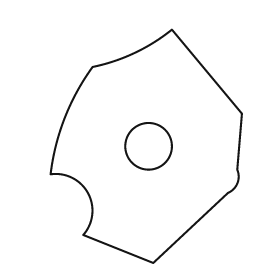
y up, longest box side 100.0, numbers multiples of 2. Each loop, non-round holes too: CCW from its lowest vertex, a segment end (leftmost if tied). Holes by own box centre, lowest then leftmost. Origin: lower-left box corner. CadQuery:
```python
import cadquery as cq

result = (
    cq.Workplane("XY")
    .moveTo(44.0, 0.0)
    .lineTo(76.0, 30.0)
    .threePointArc((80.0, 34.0), (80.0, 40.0))
    .lineTo(82.0, 64.0)
    .lineTo(52.0, 100.0)
    .threePointArc((36.0, 90.0), (18.0, 84.0))
    .threePointArc((6.0, 62.0), (0.0, 38.0))
    .threePointArc((16.0, 30.0), (14.0, 12.0))
    .close()
    .moveTo(42.0, 50.0)
    .circle(10.0)
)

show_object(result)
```